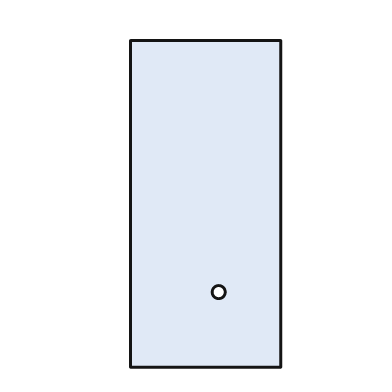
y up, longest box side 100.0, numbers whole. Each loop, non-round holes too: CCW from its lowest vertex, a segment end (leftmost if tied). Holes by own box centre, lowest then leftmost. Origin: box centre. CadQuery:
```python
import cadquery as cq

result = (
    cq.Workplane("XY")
    .moveTo(-23.0, -50.0)
    .lineTo(23.0, -50.0)
    .lineTo(23.0, 50.0)
    .lineTo(-23.0, 50.0)
    .close()
    .moveTo(4.0, -27.0)
    .circle(2.0)
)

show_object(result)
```